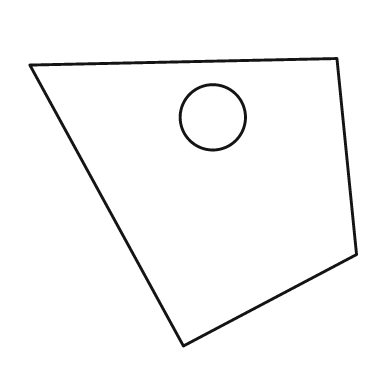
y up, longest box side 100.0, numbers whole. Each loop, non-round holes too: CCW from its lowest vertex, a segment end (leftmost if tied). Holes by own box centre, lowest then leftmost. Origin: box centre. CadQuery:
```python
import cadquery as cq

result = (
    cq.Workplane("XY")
    .moveTo(-3.0, -44.0)
    .lineTo(50.0, -16.0)
    .lineTo(44.0, 44.0)
    .lineTo(-50.0, 42.0)
    .close()
    .moveTo(6.0, 26.0)
    .circle(10.0)
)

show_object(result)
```